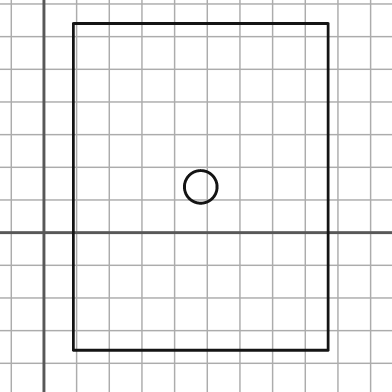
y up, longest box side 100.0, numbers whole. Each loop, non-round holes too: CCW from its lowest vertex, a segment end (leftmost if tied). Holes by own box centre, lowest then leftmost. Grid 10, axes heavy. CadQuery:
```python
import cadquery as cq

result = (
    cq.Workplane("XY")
    .moveTo(9.0, -36.0)
    .lineTo(87.0, -36.0)
    .lineTo(87.0, 64.0)
    .lineTo(9.0, 64.0)
    .close()
    .moveTo(48.0, 14.0)
    .circle(5.0)
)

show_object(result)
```